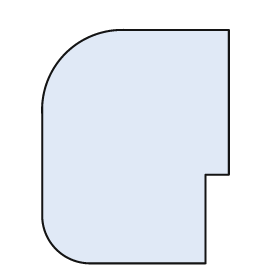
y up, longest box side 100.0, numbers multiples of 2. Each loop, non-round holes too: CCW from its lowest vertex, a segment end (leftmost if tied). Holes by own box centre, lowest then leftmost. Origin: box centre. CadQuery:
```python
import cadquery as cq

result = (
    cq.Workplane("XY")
    .moveTo(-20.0, -50.0)
    .lineTo(30.0, -50.0)
    .lineTo(30.0, -12.0)
    .lineTo(40.0, -12.0)
    .lineTo(40.0, 50.0)
    .lineTo(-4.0, 50.0)
    .threePointArc((-30.0, 40.0), (-40.0, 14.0))
    .lineTo(-40.0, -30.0)
    .threePointArc((-34.0, -44.0), (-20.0, -50.0))
    .close()
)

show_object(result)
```